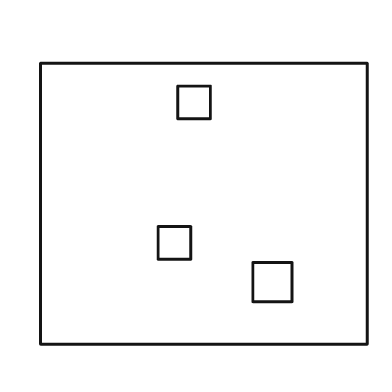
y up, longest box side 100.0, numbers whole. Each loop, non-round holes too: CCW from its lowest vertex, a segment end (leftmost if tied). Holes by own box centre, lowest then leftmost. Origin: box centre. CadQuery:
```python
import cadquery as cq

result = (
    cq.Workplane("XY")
    .moveTo(-50.0, -43.0)
    .lineTo(50.0, -43.0)
    .lineTo(50.0, 43.0)
    .lineTo(-50.0, 43.0)
    .close()
    .moveTo(15.0, -30.0)
    .lineTo(27.0, -30.0)
    .lineTo(27.0, -18.0)
    .lineTo(15.0, -18.0)
    .close()
    .moveTo(-14.0, -17.0)
    .lineTo(-4.0, -17.0)
    .lineTo(-4.0, -7.0)
    .lineTo(-14.0, -7.0)
    .close()
    .moveTo(-8.0, 26.0)
    .lineTo(2.0, 26.0)
    .lineTo(2.0, 36.0)
    .lineTo(-8.0, 36.0)
    .close()
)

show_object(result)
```